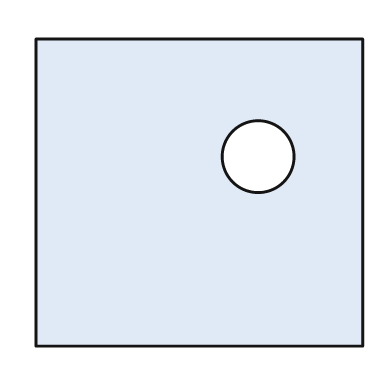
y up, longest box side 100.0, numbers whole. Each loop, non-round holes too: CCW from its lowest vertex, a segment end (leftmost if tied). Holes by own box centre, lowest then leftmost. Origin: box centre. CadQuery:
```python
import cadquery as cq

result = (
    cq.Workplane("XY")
    .moveTo(-50.0, -47.0)
    .lineTo(50.0, -47.0)
    .lineTo(50.0, 47.0)
    .lineTo(-50.0, 47.0)
    .close()
    .moveTo(18.0, 11.0)
    .circle(11.0)
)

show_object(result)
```